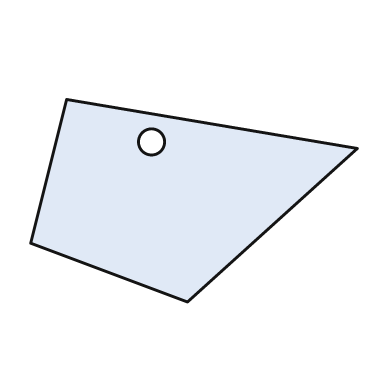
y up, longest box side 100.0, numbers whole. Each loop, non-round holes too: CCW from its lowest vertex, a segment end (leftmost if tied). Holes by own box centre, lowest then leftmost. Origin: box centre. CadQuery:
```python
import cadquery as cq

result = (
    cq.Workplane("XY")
    .moveTo(-2.0, -31.0)
    .lineTo(50.0, 16.0)
    .lineTo(-39.0, 31.0)
    .lineTo(-50.0, -13.0)
    .close()
    .moveTo(-13.0, 18.0)
    .circle(4.0)
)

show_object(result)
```